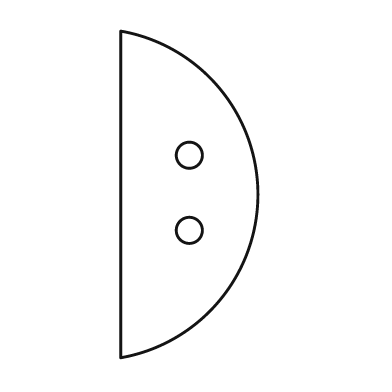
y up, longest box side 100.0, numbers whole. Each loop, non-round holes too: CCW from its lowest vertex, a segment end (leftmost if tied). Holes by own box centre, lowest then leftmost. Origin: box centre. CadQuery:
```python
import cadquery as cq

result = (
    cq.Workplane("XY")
    .moveTo(-21.0, -50.0)
    .threePointArc((21.0, 0.0), (-21.0, 50.0))
    .close()
    .moveTo(0.0, -11.0)
    .circle(4.0)
    .moveTo(0.0, 12.0)
    .circle(4.0)
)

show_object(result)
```